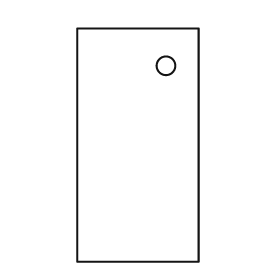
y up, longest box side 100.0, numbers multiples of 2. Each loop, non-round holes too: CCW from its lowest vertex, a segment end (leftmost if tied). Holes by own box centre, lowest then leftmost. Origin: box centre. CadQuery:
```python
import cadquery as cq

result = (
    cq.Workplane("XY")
    .moveTo(-26.0, -50.0)
    .lineTo(26.0, -50.0)
    .lineTo(26.0, 50.0)
    .lineTo(-26.0, 50.0)
    .close()
    .moveTo(12.0, 34.0)
    .circle(4.0)
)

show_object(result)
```